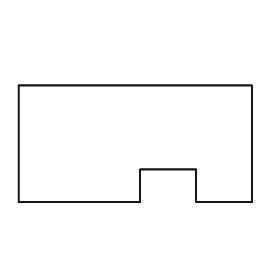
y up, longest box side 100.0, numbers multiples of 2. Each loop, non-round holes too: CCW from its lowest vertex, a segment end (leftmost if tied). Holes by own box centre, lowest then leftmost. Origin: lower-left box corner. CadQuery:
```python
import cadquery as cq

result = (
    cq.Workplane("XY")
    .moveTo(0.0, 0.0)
    .lineTo(52.0, 0.0)
    .lineTo(52.0, 14.0)
    .lineTo(76.0, 14.0)
    .lineTo(76.0, 0.0)
    .lineTo(100.0, 0.0)
    .lineTo(100.0, 50.0)
    .lineTo(0.0, 50.0)
    .close()
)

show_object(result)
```